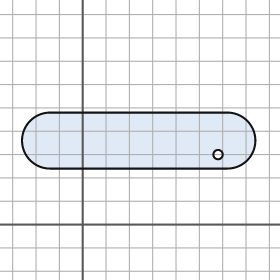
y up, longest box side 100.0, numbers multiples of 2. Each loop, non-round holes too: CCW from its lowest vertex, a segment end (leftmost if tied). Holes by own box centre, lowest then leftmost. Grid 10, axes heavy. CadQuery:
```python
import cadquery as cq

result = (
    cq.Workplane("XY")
    .moveTo(-14.0, 24.0)
    .lineTo(62.0, 24.0)
    .threePointArc((74.0, 36.0), (62.0, 48.0))
    .lineTo(-14.0, 48.0)
    .threePointArc((-26.0, 36.0), (-14.0, 24.0))
    .close()
    .moveTo(58.0, 30.0)
    .circle(2.0)
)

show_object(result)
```